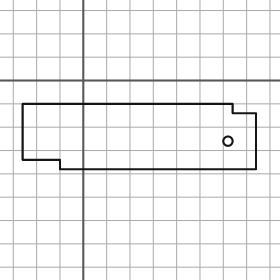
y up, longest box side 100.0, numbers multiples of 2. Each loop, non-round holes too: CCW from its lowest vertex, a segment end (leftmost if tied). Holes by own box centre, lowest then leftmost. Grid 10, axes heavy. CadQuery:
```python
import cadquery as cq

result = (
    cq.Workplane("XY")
    .moveTo(-10.0, -38.0)
    .lineTo(74.0, -38.0)
    .lineTo(74.0, -14.0)
    .lineTo(64.0, -14.0)
    .lineTo(64.0, -10.0)
    .lineTo(-26.0, -10.0)
    .lineTo(-26.0, -34.0)
    .lineTo(-10.0, -34.0)
    .close()
    .moveTo(62.0, -26.0)
    .circle(2.0)
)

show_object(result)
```